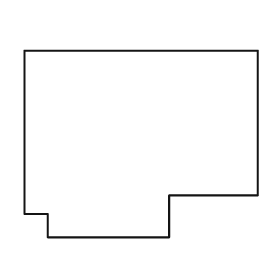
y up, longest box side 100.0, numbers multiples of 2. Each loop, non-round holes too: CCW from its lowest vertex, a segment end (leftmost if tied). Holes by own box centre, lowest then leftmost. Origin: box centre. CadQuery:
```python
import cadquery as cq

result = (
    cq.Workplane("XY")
    .moveTo(-40.0, -40.0)
    .lineTo(12.0, -40.0)
    .lineTo(12.0, -22.0)
    .lineTo(50.0, -22.0)
    .lineTo(50.0, 40.0)
    .lineTo(-50.0, 40.0)
    .lineTo(-50.0, -30.0)
    .lineTo(-40.0, -30.0)
    .close()
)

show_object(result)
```